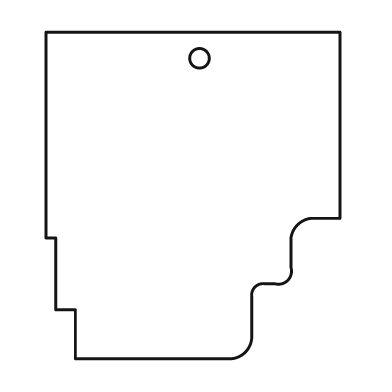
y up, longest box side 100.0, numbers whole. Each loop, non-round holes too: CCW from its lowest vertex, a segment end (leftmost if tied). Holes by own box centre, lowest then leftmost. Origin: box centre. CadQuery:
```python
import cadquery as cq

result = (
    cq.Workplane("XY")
    .moveTo(-36.0, -50.0)
    .lineTo(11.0, -50.0)
    .threePointArc((16.0, -48.0), (18.0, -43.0))
    .lineTo(18.0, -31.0)
    .threePointArc((19.0, -28.0), (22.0, -27.0))
    .lineTo(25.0, -27.0)
    .threePointArc((29.0, -26.0), (30.0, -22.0))
    .lineTo(30.0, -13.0)
    .threePointArc((32.0, -9.0), (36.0, -7.0))
    .lineTo(45.0, -7.0)
    .lineTo(45.0, 50.0)
    .lineTo(-45.0, 50.0)
    .lineTo(-45.0, -13.0)
    .lineTo(-42.0, -13.0)
    .lineTo(-42.0, -35.0)
    .lineTo(-36.0, -35.0)
    .close()
    .moveTo(2.0, 42.0)
    .circle(3.0)
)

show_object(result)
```